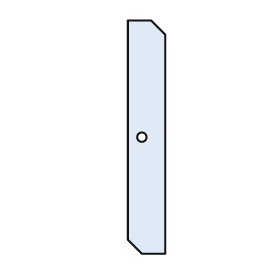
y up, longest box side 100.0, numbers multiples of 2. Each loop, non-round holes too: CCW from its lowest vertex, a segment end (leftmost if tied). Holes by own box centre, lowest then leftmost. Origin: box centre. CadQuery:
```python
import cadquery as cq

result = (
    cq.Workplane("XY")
    .moveTo(-2.0, -50.0)
    .lineTo(8.0, -50.0)
    .lineTo(8.0, 44.0)
    .lineTo(2.0, 50.0)
    .lineTo(-8.0, 50.0)
    .lineTo(-8.0, -44.0)
    .close()
    .moveTo(-2.0, 0.0)
    .circle(2.0)
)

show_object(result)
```